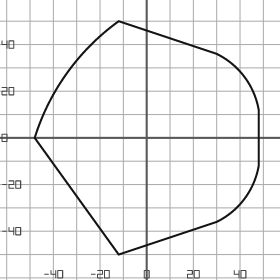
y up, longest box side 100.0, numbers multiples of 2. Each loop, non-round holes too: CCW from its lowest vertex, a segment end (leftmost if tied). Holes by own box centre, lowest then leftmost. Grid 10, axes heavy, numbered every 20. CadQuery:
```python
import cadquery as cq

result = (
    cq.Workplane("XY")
    .moveTo(-12.0, -50.0)
    .lineTo(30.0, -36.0)
    .threePointArc((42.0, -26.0), (48.0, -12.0))
    .lineTo(48.0, 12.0)
    .threePointArc((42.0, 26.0), (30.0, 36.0))
    .lineTo(-12.0, 50.0)
    .threePointArc((-34.0, 28.0), (-48.0, 0.0))
    .close()
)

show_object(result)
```